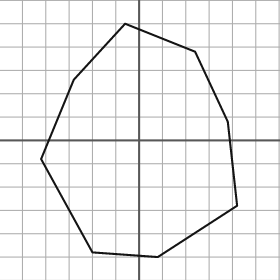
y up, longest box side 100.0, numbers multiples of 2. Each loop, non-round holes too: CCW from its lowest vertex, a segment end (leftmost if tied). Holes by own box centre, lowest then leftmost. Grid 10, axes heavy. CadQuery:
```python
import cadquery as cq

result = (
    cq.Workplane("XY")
    .moveTo(8.0, -50.0)
    .lineTo(42.0, -28.0)
    .lineTo(38.0, 8.0)
    .lineTo(24.0, 38.0)
    .lineTo(-6.0, 50.0)
    .lineTo(-28.0, 26.0)
    .lineTo(-42.0, -8.0)
    .lineTo(-20.0, -48.0)
    .close()
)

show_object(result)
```